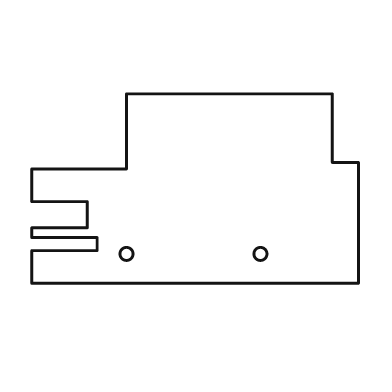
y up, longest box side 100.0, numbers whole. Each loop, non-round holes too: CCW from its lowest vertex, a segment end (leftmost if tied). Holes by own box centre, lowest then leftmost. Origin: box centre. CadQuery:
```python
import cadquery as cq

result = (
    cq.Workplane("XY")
    .moveTo(-50.0, -29.0)
    .lineTo(50.0, -29.0)
    .lineTo(50.0, 8.0)
    .lineTo(42.0, 8.0)
    .lineTo(42.0, 29.0)
    .lineTo(-21.0, 29.0)
    .lineTo(-21.0, 6.0)
    .lineTo(-50.0, 6.0)
    .lineTo(-50.0, -4.0)
    .lineTo(-33.0, -4.0)
    .lineTo(-33.0, -12.0)
    .lineTo(-50.0, -12.0)
    .lineTo(-50.0, -15.0)
    .lineTo(-30.0, -15.0)
    .lineTo(-30.0, -19.0)
    .lineTo(-50.0, -19.0)
    .close()
    .moveTo(-21.0, -20.0)
    .circle(2.0)
    .moveTo(20.0, -20.0)
    .circle(2.0)
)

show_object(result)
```